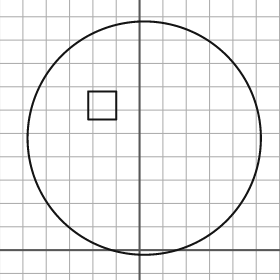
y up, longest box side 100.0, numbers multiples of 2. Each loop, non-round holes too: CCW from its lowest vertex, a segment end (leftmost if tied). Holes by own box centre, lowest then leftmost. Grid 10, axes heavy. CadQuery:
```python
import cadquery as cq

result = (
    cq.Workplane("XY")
    .moveTo(2.0, 48.0)
    .circle(50.0)
    .moveTo(-22.0, 56.0)
    .lineTo(-10.0, 56.0)
    .lineTo(-10.0, 68.0)
    .lineTo(-22.0, 68.0)
    .close()
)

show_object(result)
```